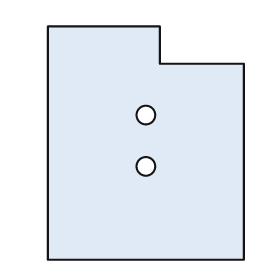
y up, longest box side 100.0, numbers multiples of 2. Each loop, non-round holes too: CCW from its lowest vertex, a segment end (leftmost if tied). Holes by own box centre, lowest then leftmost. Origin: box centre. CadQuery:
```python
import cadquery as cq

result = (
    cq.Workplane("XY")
    .moveTo(-42.0, -50.0)
    .lineTo(42.0, -50.0)
    .lineTo(42.0, 34.0)
    .lineTo(6.0, 34.0)
    .lineTo(6.0, 50.0)
    .lineTo(-42.0, 50.0)
    .close()
    .moveTo(0.0, -10.0)
    .circle(4.0)
    .moveTo(0.0, 12.0)
    .circle(4.0)
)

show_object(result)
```